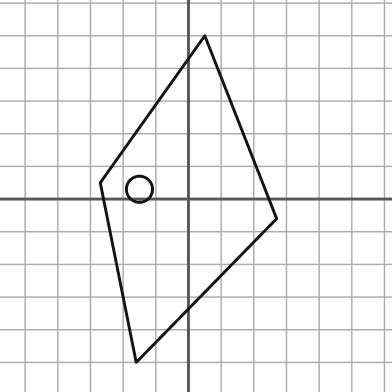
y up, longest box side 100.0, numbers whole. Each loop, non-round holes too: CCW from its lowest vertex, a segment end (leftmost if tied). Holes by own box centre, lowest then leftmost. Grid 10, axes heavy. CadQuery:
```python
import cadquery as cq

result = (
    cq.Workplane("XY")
    .moveTo(-16.0, -50.0)
    .lineTo(27.0, -6.0)
    .lineTo(5.0, 50.0)
    .lineTo(-27.0, 5.0)
    .close()
    .moveTo(-15.0, 3.0)
    .circle(4.0)
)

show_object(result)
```